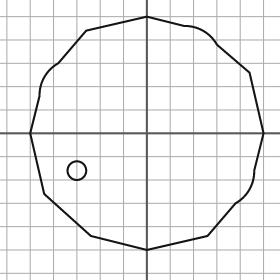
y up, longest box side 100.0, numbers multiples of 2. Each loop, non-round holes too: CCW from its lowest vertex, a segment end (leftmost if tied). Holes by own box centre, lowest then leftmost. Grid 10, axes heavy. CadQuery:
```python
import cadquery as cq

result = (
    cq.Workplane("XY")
    .moveTo(0.0, -50.0)
    .lineTo(26.0, -44.0)
    .lineTo(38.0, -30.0)
    .threePointArc((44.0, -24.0), (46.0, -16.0))
    .lineTo(50.0, 0.0)
    .lineTo(44.0, 26.0)
    .lineTo(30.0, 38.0)
    .threePointArc((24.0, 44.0), (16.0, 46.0))
    .lineTo(0.0, 50.0)
    .lineTo(-26.0, 44.0)
    .lineTo(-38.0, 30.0)
    .threePointArc((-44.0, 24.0), (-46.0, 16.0))
    .lineTo(-50.0, 0.0)
    .lineTo(-44.0, -26.0)
    .lineTo(-24.0, -44.0)
    .close()
    .moveTo(-30.0, -16.0)
    .circle(4.0)
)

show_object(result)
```